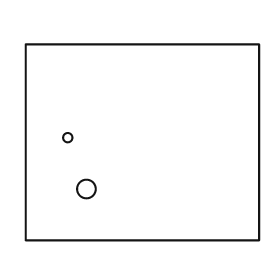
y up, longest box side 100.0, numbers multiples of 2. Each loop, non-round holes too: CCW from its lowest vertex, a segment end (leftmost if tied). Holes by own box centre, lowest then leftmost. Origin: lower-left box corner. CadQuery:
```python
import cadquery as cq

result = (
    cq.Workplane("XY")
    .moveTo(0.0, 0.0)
    .lineTo(100.0, 0.0)
    .lineTo(100.0, 84.0)
    .lineTo(0.0, 84.0)
    .close()
    .moveTo(26.0, 22.0)
    .circle(4.0)
    .moveTo(18.0, 44.0)
    .circle(2.0)
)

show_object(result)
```